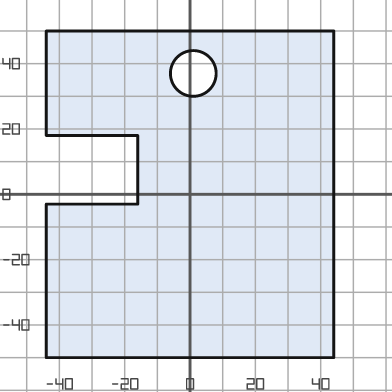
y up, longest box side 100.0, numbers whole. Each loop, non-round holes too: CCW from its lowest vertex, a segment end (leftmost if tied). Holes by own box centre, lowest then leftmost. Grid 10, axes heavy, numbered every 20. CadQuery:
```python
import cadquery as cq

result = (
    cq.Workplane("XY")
    .moveTo(-44.0, -50.0)
    .lineTo(44.0, -50.0)
    .lineTo(44.0, 50.0)
    .lineTo(-44.0, 50.0)
    .lineTo(-44.0, 18.0)
    .lineTo(-16.0, 18.0)
    .lineTo(-16.0, -3.0)
    .lineTo(-44.0, -3.0)
    .close()
    .moveTo(1.0, 37.0)
    .circle(7.0)
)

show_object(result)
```